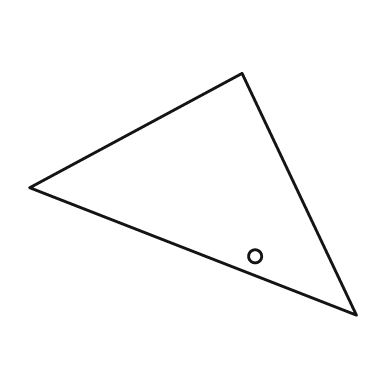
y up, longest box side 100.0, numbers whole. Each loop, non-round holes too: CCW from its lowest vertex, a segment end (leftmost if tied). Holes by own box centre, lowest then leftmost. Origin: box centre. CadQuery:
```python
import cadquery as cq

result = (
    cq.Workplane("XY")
    .moveTo(50.0, -37.0)
    .lineTo(15.0, 37.0)
    .lineTo(-50.0, 2.0)
    .close()
    .moveTo(19.0, -19.0)
    .circle(2.0)
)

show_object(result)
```